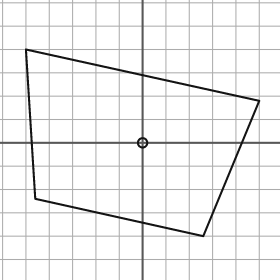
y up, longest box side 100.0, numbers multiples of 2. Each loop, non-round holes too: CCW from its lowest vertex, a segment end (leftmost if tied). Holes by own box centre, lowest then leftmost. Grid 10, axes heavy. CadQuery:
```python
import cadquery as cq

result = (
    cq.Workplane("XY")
    .moveTo(26.0, -40.0)
    .lineTo(50.0, 18.0)
    .lineTo(-50.0, 40.0)
    .lineTo(-46.0, -24.0)
    .close()
    .moveTo(0.0, 0.0)
    .circle(2.0)
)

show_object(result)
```